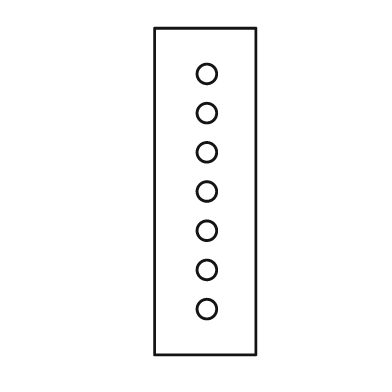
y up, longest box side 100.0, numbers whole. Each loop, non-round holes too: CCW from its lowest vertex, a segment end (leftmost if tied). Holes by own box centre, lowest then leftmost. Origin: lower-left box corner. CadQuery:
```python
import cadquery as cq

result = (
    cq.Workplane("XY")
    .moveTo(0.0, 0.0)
    .lineTo(31.0, 0.0)
    .lineTo(31.0, 100.0)
    .lineTo(0.0, 100.0)
    .close()
    .moveTo(16.0, 14.0)
    .circle(3.0)
    .moveTo(16.0, 26.0)
    .circle(3.0)
    .moveTo(16.0, 38.0)
    .circle(3.0)
    .moveTo(16.0, 50.0)
    .circle(3.0)
    .moveTo(16.0, 62.0)
    .circle(3.0)
    .moveTo(16.0, 74.0)
    .circle(3.0)
    .moveTo(16.0, 86.0)
    .circle(3.0)
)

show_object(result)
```